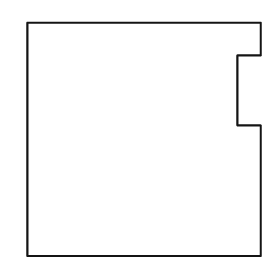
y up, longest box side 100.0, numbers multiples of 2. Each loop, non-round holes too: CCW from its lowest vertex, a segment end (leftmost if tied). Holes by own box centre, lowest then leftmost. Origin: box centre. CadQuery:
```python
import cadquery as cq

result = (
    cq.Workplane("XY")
    .moveTo(-50.0, -50.0)
    .lineTo(50.0, -50.0)
    .lineTo(50.0, 6.0)
    .lineTo(40.0, 6.0)
    .lineTo(40.0, 36.0)
    .lineTo(50.0, 36.0)
    .lineTo(50.0, 50.0)
    .lineTo(-50.0, 50.0)
    .close()
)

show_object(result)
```